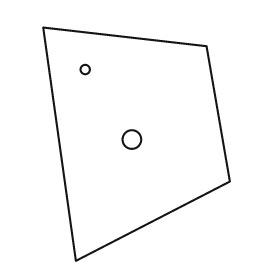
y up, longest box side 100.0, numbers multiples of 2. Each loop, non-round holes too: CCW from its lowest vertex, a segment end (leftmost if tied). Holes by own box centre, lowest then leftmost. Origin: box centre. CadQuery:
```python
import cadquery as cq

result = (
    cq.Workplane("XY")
    .moveTo(-26.0, -50.0)
    .lineTo(40.0, -16.0)
    .lineTo(30.0, 42.0)
    .lineTo(-40.0, 50.0)
    .close()
    .moveTo(-2.0, 2.0)
    .circle(4.0)
    .moveTo(-22.0, 32.0)
    .circle(2.0)
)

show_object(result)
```